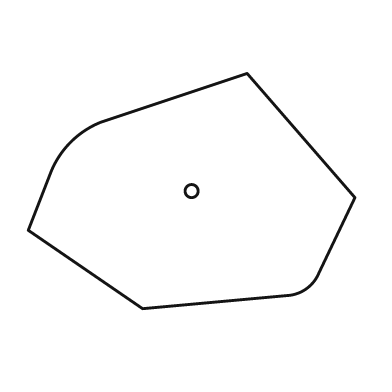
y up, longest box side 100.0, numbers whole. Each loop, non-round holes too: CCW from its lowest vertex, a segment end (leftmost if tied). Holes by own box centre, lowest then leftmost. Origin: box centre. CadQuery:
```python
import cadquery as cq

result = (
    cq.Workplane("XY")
    .moveTo(-15.0, -36.0)
    .lineTo(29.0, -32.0)
    .threePointArc((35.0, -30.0), (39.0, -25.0))
    .lineTo(50.0, -2.0)
    .lineTo(17.0, 36.0)
    .lineTo(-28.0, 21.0)
    .threePointArc((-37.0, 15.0), (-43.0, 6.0))
    .lineTo(-50.0, -12.0)
    .close()
    .moveTo(0.0, 0.0)
    .circle(2.0)
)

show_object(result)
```